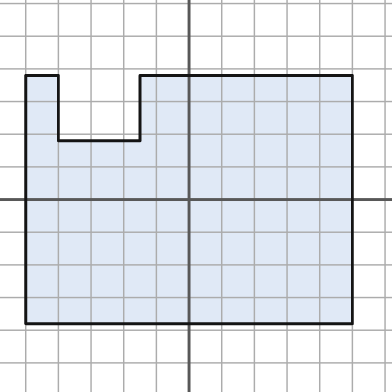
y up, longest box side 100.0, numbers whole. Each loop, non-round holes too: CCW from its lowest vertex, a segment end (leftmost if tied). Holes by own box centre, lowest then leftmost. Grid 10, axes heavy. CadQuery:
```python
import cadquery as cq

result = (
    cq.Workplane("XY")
    .moveTo(-50.0, -38.0)
    .lineTo(50.0, -38.0)
    .lineTo(50.0, 38.0)
    .lineTo(-15.0, 38.0)
    .lineTo(-15.0, 18.0)
    .lineTo(-40.0, 18.0)
    .lineTo(-40.0, 38.0)
    .lineTo(-50.0, 38.0)
    .close()
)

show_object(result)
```